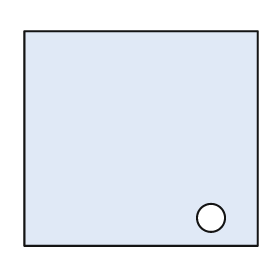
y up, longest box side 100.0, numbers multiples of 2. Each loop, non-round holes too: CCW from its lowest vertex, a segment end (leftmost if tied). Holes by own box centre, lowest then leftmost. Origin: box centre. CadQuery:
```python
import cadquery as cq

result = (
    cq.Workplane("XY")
    .moveTo(-50.0, -46.0)
    .lineTo(50.0, -46.0)
    .lineTo(50.0, 46.0)
    .lineTo(-50.0, 46.0)
    .close()
    .moveTo(30.0, -34.0)
    .circle(6.0)
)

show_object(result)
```